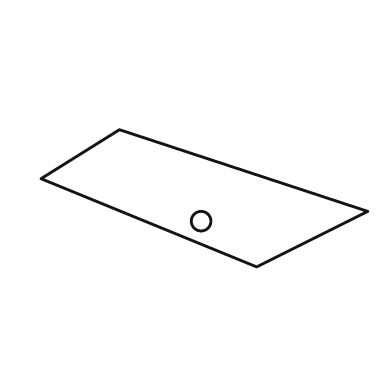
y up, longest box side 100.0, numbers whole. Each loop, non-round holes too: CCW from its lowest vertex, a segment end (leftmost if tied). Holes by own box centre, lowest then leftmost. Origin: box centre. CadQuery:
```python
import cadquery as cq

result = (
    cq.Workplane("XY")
    .moveTo(16.0, -21.0)
    .lineTo(50.0, -4.0)
    .lineTo(-26.0, 21.0)
    .lineTo(-50.0, 6.0)
    .close()
    .moveTo(-1.0, -7.0)
    .circle(3.0)
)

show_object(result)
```